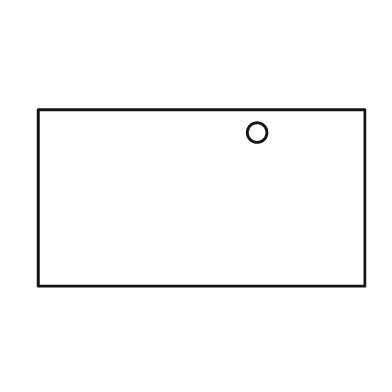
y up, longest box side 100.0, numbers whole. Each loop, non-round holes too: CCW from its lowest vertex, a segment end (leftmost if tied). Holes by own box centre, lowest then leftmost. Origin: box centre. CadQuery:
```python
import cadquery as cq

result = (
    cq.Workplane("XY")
    .moveTo(-50.0, -27.0)
    .lineTo(50.0, -27.0)
    .lineTo(50.0, 27.0)
    .lineTo(-50.0, 27.0)
    .close()
    .moveTo(17.0, 20.0)
    .circle(3.0)
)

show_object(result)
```